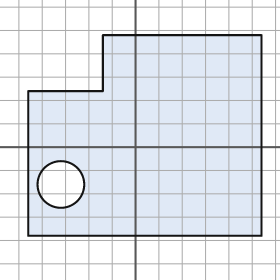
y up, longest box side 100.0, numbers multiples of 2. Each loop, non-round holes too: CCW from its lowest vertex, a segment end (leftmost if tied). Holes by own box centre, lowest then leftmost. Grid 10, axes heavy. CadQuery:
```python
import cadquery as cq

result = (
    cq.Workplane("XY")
    .moveTo(-46.0, -38.0)
    .lineTo(54.0, -38.0)
    .lineTo(54.0, 48.0)
    .lineTo(-14.0, 48.0)
    .lineTo(-14.0, 24.0)
    .lineTo(-46.0, 24.0)
    .close()
    .moveTo(-32.0, -16.0)
    .circle(10.0)
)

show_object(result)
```